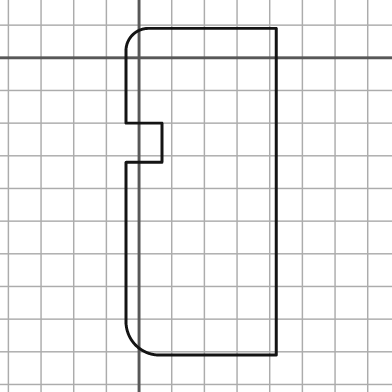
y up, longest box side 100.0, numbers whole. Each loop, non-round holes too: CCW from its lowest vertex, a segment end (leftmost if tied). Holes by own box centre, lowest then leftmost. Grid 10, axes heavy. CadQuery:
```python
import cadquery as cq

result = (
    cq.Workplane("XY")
    .moveTo(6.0, -91.0)
    .lineTo(42.0, -91.0)
    .lineTo(42.0, 9.0)
    .lineTo(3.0, 9.0)
    .threePointArc((-2.0, 7.0), (-4.0, 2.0))
    .lineTo(-4.0, -20.0)
    .lineTo(7.0, -20.0)
    .lineTo(7.0, -32.0)
    .lineTo(-4.0, -32.0)
    .lineTo(-4.0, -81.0)
    .threePointArc((-1.0, -88.0), (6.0, -91.0))
    .close()
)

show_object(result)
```